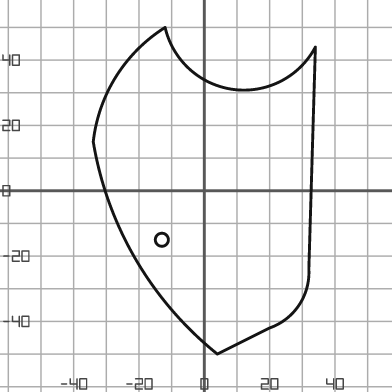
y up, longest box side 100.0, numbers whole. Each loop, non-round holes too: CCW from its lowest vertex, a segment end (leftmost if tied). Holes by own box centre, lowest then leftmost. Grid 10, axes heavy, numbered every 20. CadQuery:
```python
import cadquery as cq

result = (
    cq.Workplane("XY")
    .moveTo(4.0, -50.0)
    .lineTo(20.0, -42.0)
    .threePointArc((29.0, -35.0), (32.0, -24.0))
    .lineTo(34.0, 44.0)
    .threePointArc((9.0, 31.0), (-12.0, 50.0))
    .threePointArc((-27.0, 35.0), (-34.0, 15.0))
    .threePointArc((-21.0, -21.0), (4.0, -50.0))
    .close()
    .moveTo(-13.0, -15.0)
    .circle(2.0)
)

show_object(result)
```